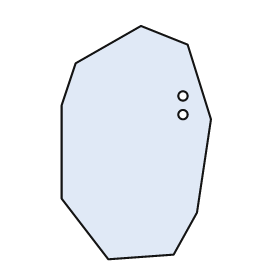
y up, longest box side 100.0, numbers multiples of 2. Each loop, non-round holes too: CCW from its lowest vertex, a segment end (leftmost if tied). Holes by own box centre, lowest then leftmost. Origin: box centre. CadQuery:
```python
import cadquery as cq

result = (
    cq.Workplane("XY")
    .moveTo(-12.0, -50.0)
    .lineTo(16.0, -48.0)
    .lineTo(26.0, -30.0)
    .lineTo(32.0, 10.0)
    .lineTo(22.0, 42.0)
    .lineTo(2.0, 50.0)
    .lineTo(-26.0, 34.0)
    .lineTo(-32.0, 16.0)
    .lineTo(-32.0, -24.0)
    .close()
    .moveTo(20.0, 12.0)
    .circle(2.0)
    .moveTo(20.0, 20.0)
    .circle(2.0)
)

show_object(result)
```